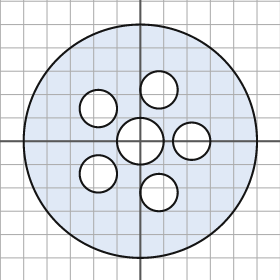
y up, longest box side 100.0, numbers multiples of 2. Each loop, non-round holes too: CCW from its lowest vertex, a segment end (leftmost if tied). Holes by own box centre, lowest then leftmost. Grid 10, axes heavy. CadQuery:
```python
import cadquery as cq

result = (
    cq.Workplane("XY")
    .moveTo(0.0, 0.0)
    .circle(50.0)
    .moveTo(8.0, -22.0)
    .circle(8.0)
    .moveTo(-18.0, -14.0)
    .circle(8.0)
    .moveTo(0.0, 0.0)
    .circle(10.0)
    .moveTo(22.0, 0.0)
    .circle(8.0)
    .moveTo(-18.0, 14.0)
    .circle(8.0)
    .moveTo(8.0, 22.0)
    .circle(8.0)
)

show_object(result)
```